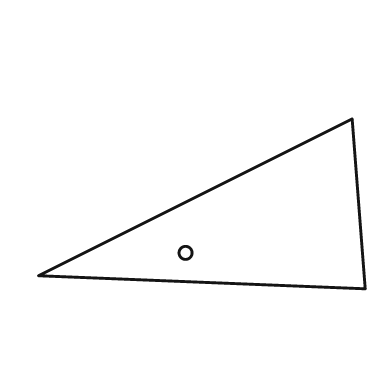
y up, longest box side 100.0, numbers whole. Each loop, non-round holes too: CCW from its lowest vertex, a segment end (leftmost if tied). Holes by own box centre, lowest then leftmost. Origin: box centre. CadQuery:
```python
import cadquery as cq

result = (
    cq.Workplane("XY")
    .moveTo(50.0, -26.0)
    .lineTo(46.0, 26.0)
    .lineTo(-50.0, -22.0)
    .close()
    .moveTo(-5.0, -15.0)
    .circle(2.0)
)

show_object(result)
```